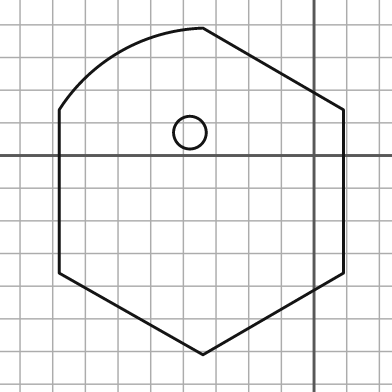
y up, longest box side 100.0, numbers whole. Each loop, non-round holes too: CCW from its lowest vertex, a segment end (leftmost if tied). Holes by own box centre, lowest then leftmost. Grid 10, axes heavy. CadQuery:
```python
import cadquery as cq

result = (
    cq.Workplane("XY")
    .moveTo(-34.0, -61.0)
    .lineTo(9.0, -36.0)
    .lineTo(9.0, 14.0)
    .lineTo(-34.0, 39.0)
    .threePointArc((-59.0, 32.0), (-78.0, 14.0))
    .lineTo(-78.0, -36.0)
    .close()
    .moveTo(-38.0, 7.0)
    .circle(5.0)
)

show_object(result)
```